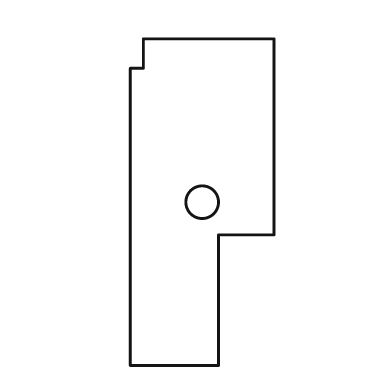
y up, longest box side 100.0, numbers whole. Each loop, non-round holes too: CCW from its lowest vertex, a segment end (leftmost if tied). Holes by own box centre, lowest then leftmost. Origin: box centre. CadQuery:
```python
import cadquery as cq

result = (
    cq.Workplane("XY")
    .moveTo(-22.0, -50.0)
    .lineTo(5.0, -50.0)
    .lineTo(5.0, -10.0)
    .lineTo(22.0, -10.0)
    .lineTo(22.0, 50.0)
    .lineTo(-18.0, 50.0)
    .lineTo(-18.0, 41.0)
    .lineTo(-22.0, 41.0)
    .close()
    .moveTo(0.0, 0.0)
    .circle(5.0)
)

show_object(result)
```